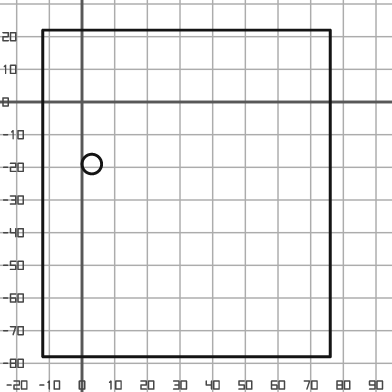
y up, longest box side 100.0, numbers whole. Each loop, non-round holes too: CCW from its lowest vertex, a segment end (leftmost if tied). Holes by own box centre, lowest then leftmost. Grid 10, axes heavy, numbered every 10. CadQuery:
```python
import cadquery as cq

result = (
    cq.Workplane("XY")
    .moveTo(-12.0, -78.0)
    .lineTo(76.0, -78.0)
    .lineTo(76.0, 22.0)
    .lineTo(-12.0, 22.0)
    .close()
    .moveTo(3.0, -19.0)
    .circle(3.0)
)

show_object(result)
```